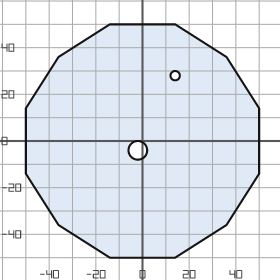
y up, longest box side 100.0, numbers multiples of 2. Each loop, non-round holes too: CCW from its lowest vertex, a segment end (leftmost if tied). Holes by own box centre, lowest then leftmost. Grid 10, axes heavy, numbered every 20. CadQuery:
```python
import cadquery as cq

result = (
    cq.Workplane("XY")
    .moveTo(-14.0, -50.0)
    .lineTo(14.0, -50.0)
    .lineTo(36.0, -36.0)
    .lineTo(50.0, -14.0)
    .lineTo(50.0, 14.0)
    .lineTo(36.0, 36.0)
    .lineTo(14.0, 50.0)
    .lineTo(-14.0, 50.0)
    .lineTo(-36.0, 36.0)
    .lineTo(-50.0, 14.0)
    .lineTo(-50.0, -14.0)
    .lineTo(-36.0, -36.0)
    .close()
    .moveTo(-2.0, -4.0)
    .circle(4.0)
    .moveTo(14.0, 28.0)
    .circle(2.0)
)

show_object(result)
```